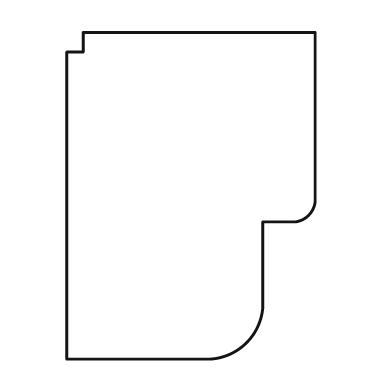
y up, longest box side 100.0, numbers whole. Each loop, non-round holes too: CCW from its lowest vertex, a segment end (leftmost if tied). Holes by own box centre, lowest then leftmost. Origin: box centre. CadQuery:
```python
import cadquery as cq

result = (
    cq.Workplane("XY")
    .moveTo(-38.0, -50.0)
    .lineTo(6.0, -50.0)
    .threePointArc((17.0, -45.0), (22.0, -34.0))
    .lineTo(22.0, -8.0)
    .lineTo(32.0, -8.0)
    .threePointArc((36.0, -6.0), (38.0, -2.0))
    .lineTo(38.0, 50.0)
    .lineTo(-33.0, 50.0)
    .lineTo(-33.0, 44.0)
    .lineTo(-38.0, 44.0)
    .close()
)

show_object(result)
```